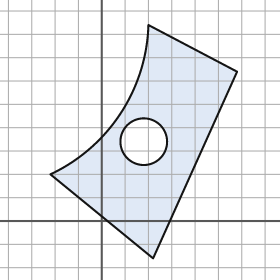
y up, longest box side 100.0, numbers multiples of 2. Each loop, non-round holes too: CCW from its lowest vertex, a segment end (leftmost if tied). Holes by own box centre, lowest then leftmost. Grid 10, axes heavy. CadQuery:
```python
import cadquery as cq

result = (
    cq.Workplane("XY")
    .moveTo(22.0, -16.0)
    .lineTo(58.0, 64.0)
    .lineTo(20.0, 84.0)
    .threePointArc((8.0, 46.0), (-22.0, 20.0))
    .close()
    .moveTo(18.0, 34.0)
    .circle(10.0)
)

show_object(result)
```